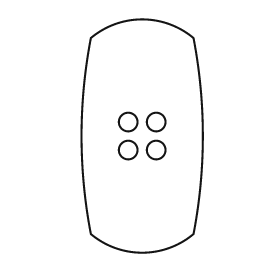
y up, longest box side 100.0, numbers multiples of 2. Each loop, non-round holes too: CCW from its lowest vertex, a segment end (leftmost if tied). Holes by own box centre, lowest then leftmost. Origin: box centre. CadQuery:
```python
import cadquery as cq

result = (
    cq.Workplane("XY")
    .moveTo(-22.0, -42.0)
    .threePointArc((0.0, -50.0), (22.0, -42.0))
    .threePointArc((26.0, 0.0), (22.0, 42.0))
    .threePointArc((0.0, 50.0), (-22.0, 42.0))
    .threePointArc((-26.0, 0.0), (-22.0, -42.0))
    .close()
    .moveTo(-6.0, -6.0)
    .circle(4.0)
    .moveTo(6.0, -6.0)
    .circle(4.0)
    .moveTo(-6.0, 6.0)
    .circle(4.0)
    .moveTo(6.0, 6.0)
    .circle(4.0)
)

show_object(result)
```